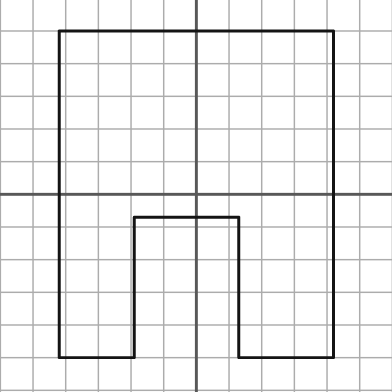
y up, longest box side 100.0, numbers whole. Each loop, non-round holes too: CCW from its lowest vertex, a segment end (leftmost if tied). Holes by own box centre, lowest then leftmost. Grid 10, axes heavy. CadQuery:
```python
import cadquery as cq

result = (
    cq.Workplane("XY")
    .moveTo(-42.0, -50.0)
    .lineTo(-19.0, -50.0)
    .lineTo(-19.0, -7.0)
    .lineTo(13.0, -7.0)
    .lineTo(13.0, -50.0)
    .lineTo(42.0, -50.0)
    .lineTo(42.0, 50.0)
    .lineTo(-42.0, 50.0)
    .close()
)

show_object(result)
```